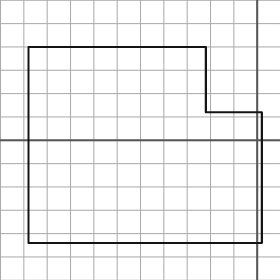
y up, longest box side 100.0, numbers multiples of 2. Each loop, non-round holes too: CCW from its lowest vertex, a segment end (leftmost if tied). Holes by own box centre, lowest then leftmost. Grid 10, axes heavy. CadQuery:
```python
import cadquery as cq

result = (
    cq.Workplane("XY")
    .moveTo(-98.0, -44.0)
    .lineTo(2.0, -44.0)
    .lineTo(2.0, 12.0)
    .lineTo(-22.0, 12.0)
    .lineTo(-22.0, 40.0)
    .lineTo(-98.0, 40.0)
    .close()
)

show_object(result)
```